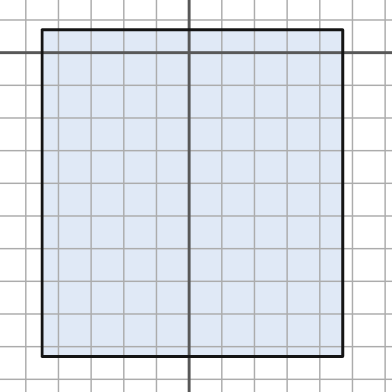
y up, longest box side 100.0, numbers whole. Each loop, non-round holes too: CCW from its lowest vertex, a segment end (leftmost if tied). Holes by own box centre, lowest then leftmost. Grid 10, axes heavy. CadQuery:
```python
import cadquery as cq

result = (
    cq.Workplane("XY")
    .moveTo(-45.0, -93.0)
    .lineTo(47.0, -93.0)
    .lineTo(47.0, 7.0)
    .lineTo(-45.0, 7.0)
    .close()
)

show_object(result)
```